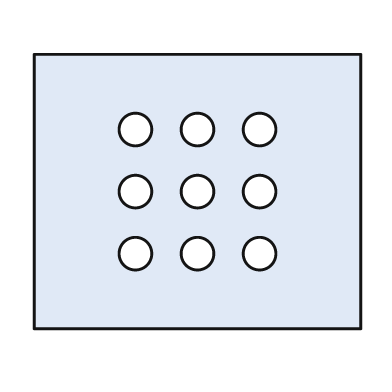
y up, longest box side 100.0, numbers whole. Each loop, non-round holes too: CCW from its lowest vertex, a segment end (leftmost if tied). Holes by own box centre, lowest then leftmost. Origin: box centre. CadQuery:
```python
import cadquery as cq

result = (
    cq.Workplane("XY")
    .moveTo(-50.0, -42.0)
    .lineTo(50.0, -42.0)
    .lineTo(50.0, 42.0)
    .lineTo(-50.0, 42.0)
    .close()
    .moveTo(-19.0, -19.0)
    .circle(5.0)
    .moveTo(0.0, -19.0)
    .circle(5.0)
    .moveTo(19.0, -19.0)
    .circle(5.0)
    .moveTo(-19.0, 0.0)
    .circle(5.0)
    .moveTo(0.0, 0.0)
    .circle(5.0)
    .moveTo(19.0, 0.0)
    .circle(5.0)
    .moveTo(-19.0, 19.0)
    .circle(5.0)
    .moveTo(0.0, 19.0)
    .circle(5.0)
    .moveTo(19.0, 19.0)
    .circle(5.0)
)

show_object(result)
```